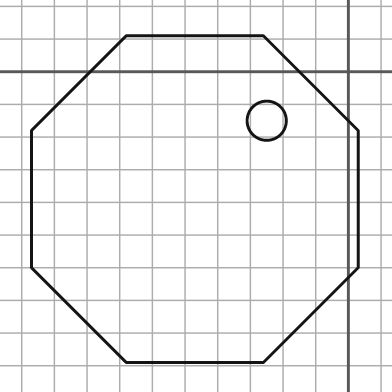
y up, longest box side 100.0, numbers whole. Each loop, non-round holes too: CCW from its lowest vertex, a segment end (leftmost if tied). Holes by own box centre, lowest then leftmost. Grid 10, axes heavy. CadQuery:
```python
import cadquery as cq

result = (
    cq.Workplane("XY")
    .moveTo(-68.0, -89.0)
    .lineTo(-26.0, -89.0)
    .lineTo(3.0, -60.0)
    .lineTo(3.0, -18.0)
    .lineTo(-26.0, 11.0)
    .lineTo(-68.0, 11.0)
    .lineTo(-97.0, -18.0)
    .lineTo(-97.0, -60.0)
    .close()
    .moveTo(-25.0, -15.0)
    .circle(6.0)
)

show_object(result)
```